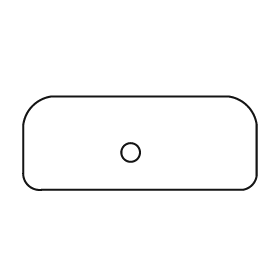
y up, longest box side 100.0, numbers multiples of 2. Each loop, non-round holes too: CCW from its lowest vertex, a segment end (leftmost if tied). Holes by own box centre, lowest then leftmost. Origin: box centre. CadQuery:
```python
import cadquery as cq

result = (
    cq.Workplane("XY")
    .moveTo(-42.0, -20.0)
    .lineTo(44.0, -20.0)
    .threePointArc((48.0, -18.0), (50.0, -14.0))
    .lineTo(50.0, 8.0)
    .threePointArc((46.0, 16.0), (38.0, 20.0))
    .lineTo(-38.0, 20.0)
    .threePointArc((-46.0, 16.0), (-50.0, 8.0))
    .lineTo(-50.0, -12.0)
    .threePointArc((-48.0, -18.0), (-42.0, -20.0))
    .close()
    .moveTo(-4.0, -4.0)
    .circle(4.0)
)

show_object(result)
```